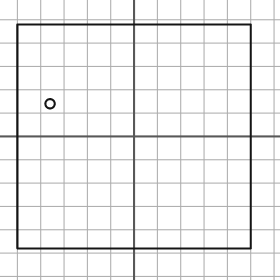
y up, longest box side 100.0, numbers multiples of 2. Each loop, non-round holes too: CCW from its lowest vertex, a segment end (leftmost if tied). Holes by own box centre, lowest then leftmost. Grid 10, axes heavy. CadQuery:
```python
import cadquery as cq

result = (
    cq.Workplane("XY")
    .moveTo(-50.0, -48.0)
    .lineTo(50.0, -48.0)
    .lineTo(50.0, 48.0)
    .lineTo(-50.0, 48.0)
    .close()
    .moveTo(-36.0, 14.0)
    .circle(2.0)
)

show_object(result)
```